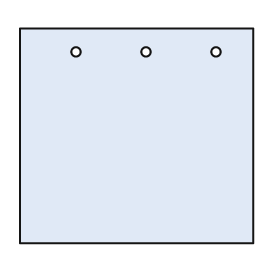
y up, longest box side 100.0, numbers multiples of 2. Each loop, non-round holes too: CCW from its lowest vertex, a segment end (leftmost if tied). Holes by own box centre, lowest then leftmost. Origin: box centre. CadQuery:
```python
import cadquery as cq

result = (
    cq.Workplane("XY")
    .moveTo(-50.0, -46.0)
    .lineTo(50.0, -46.0)
    .lineTo(50.0, 46.0)
    .lineTo(-50.0, 46.0)
    .close()
    .moveTo(-26.0, 36.0)
    .circle(2.0)
    .moveTo(4.0, 36.0)
    .circle(2.0)
    .moveTo(34.0, 36.0)
    .circle(2.0)
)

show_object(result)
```